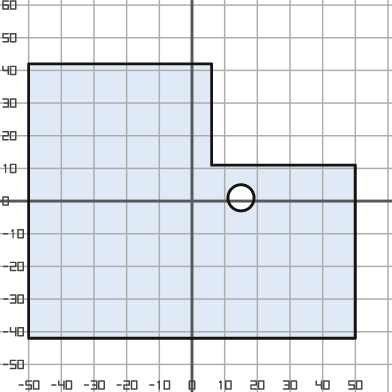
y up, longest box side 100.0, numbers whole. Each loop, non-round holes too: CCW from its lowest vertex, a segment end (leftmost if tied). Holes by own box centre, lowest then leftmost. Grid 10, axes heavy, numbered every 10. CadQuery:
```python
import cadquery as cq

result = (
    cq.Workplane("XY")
    .moveTo(-50.0, -42.0)
    .lineTo(50.0, -42.0)
    .lineTo(50.0, 11.0)
    .lineTo(6.0, 11.0)
    .lineTo(6.0, 42.0)
    .lineTo(-50.0, 42.0)
    .close()
    .moveTo(15.0, 1.0)
    .circle(4.0)
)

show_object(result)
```